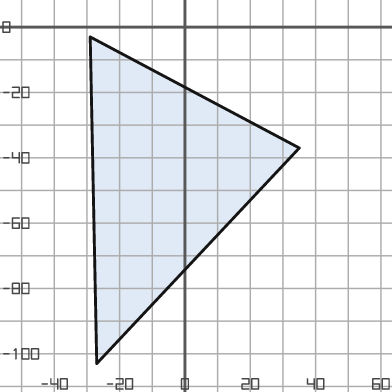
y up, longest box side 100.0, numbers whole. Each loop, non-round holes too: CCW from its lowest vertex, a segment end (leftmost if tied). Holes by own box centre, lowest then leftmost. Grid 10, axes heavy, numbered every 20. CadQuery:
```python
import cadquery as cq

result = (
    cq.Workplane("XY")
    .moveTo(-27.0, -103.0)
    .lineTo(35.0, -37.0)
    .lineTo(-29.0, -3.0)
    .close()
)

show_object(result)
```